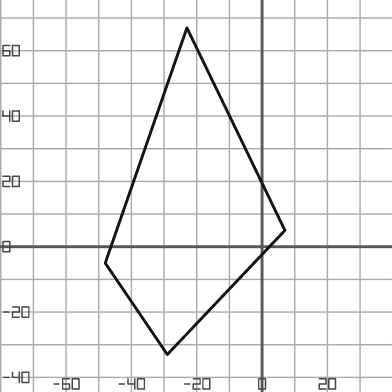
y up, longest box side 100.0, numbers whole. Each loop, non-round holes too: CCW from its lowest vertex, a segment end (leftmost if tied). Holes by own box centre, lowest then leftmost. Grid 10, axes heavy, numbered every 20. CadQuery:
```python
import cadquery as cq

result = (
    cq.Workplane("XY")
    .moveTo(-29.0, -33.0)
    .lineTo(7.0, 5.0)
    .lineTo(-23.0, 67.0)
    .lineTo(-48.0, -5.0)
    .close()
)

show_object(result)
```